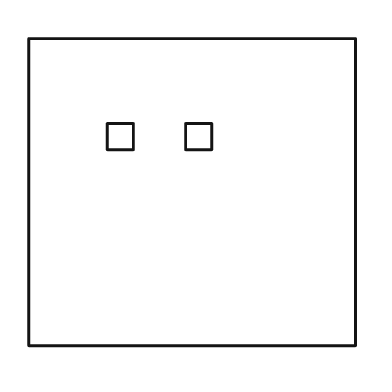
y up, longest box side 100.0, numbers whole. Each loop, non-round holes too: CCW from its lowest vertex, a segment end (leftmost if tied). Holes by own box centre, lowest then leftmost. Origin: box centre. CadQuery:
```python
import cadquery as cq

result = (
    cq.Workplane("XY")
    .moveTo(-50.0, -47.0)
    .lineTo(50.0, -47.0)
    .lineTo(50.0, 47.0)
    .lineTo(-50.0, 47.0)
    .close()
    .moveTo(-26.0, 13.0)
    .lineTo(-18.0, 13.0)
    .lineTo(-18.0, 21.0)
    .lineTo(-26.0, 21.0)
    .close()
    .moveTo(-2.0, 13.0)
    .lineTo(6.0, 13.0)
    .lineTo(6.0, 21.0)
    .lineTo(-2.0, 21.0)
    .close()
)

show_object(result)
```